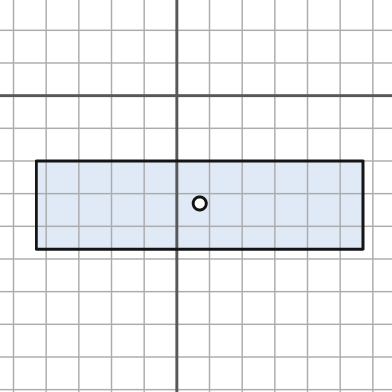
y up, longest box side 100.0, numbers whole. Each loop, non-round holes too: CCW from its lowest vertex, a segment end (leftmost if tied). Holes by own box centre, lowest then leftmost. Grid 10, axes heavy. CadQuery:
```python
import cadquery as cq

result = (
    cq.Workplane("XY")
    .moveTo(-43.0, -47.0)
    .lineTo(57.0, -47.0)
    .lineTo(57.0, -20.0)
    .lineTo(-43.0, -20.0)
    .close()
    .moveTo(7.0, -33.0)
    .circle(2.0)
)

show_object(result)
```